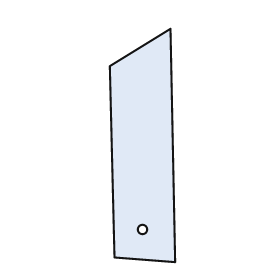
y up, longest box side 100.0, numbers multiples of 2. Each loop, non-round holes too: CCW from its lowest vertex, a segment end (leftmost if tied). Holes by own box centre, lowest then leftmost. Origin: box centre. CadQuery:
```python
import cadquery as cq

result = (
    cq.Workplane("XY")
    .moveTo(14.0, -50.0)
    .lineTo(12.0, 50.0)
    .lineTo(-14.0, 34.0)
    .lineTo(-12.0, -48.0)
    .close()
    .moveTo(0.0, -36.0)
    .circle(2.0)
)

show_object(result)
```